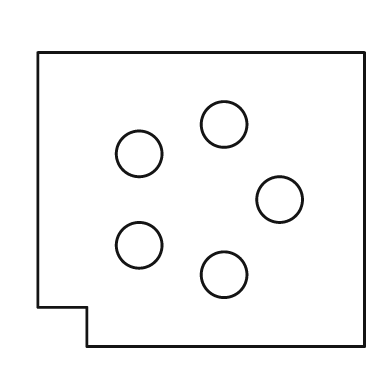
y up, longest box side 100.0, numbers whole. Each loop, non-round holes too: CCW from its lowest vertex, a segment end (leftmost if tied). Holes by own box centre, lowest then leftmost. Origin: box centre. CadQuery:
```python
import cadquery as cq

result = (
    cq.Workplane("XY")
    .moveTo(-35.0, -45.0)
    .lineTo(50.0, -45.0)
    .lineTo(50.0, 45.0)
    .lineTo(-50.0, 45.0)
    .lineTo(-50.0, -33.0)
    .lineTo(-35.0, -33.0)
    .close()
    .moveTo(7.0, -23.0)
    .circle(7.0)
    .moveTo(-19.0, -14.0)
    .circle(7.0)
    .moveTo(24.0, 0.0)
    .circle(7.0)
    .moveTo(-19.0, 14.0)
    .circle(7.0)
    .moveTo(7.0, 23.0)
    .circle(7.0)
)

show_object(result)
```